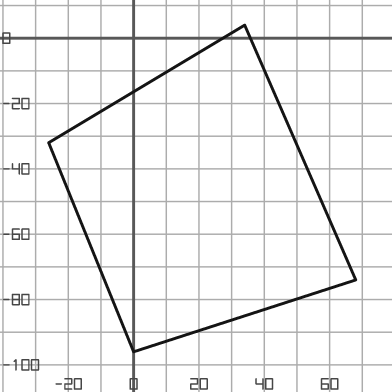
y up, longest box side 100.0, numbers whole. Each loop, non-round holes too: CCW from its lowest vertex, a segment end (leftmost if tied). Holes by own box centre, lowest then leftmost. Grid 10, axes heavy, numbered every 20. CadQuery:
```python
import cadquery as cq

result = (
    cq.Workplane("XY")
    .moveTo(0.0, -96.0)
    .lineTo(68.0, -74.0)
    .lineTo(34.0, 4.0)
    .lineTo(-26.0, -32.0)
    .close()
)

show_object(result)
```